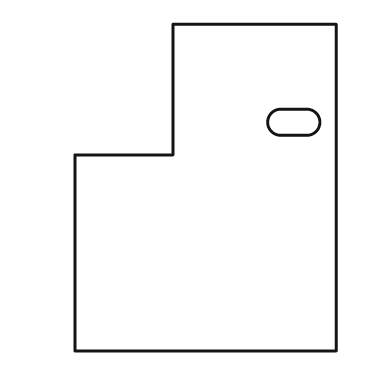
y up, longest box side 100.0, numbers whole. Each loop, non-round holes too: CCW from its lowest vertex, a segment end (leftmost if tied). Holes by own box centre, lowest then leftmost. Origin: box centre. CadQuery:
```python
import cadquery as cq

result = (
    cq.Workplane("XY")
    .moveTo(-40.0, -50.0)
    .lineTo(40.0, -50.0)
    .lineTo(40.0, 50.0)
    .lineTo(-10.0, 50.0)
    .lineTo(-10.0, 10.0)
    .lineTo(-40.0, 10.0)
    .close()
    .moveTo(23.0, 16.0)
    .lineTo(31.0, 16.0)
    .threePointArc((35.0, 20.0), (31.0, 24.0))
    .lineTo(23.0, 24.0)
    .threePointArc((19.0, 20.0), (23.0, 16.0))
    .close()
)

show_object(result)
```